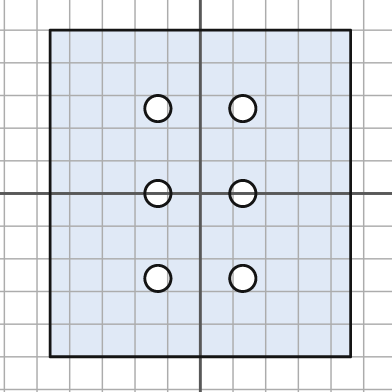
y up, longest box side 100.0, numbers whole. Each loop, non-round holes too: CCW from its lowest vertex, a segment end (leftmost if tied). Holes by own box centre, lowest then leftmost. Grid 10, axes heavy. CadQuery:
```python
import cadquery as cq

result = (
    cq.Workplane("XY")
    .moveTo(-46.0, -50.0)
    .lineTo(46.0, -50.0)
    .lineTo(46.0, 50.0)
    .lineTo(-46.0, 50.0)
    .close()
    .moveTo(-13.0, -26.0)
    .circle(4.0)
    .moveTo(13.0, -26.0)
    .circle(4.0)
    .moveTo(-13.0, 0.0)
    .circle(4.0)
    .moveTo(13.0, 0.0)
    .circle(4.0)
    .moveTo(-13.0, 26.0)
    .circle(4.0)
    .moveTo(13.0, 26.0)
    .circle(4.0)
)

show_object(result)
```